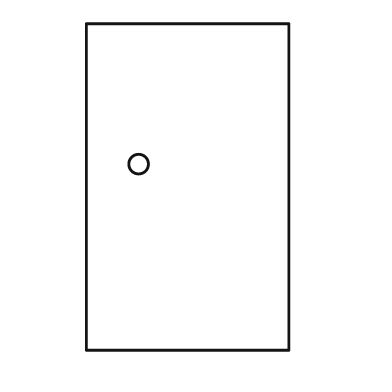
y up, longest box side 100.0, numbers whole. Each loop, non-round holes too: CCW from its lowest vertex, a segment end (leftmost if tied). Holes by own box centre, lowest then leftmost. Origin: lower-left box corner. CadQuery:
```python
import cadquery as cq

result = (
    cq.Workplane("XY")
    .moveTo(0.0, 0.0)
    .lineTo(62.0, 0.0)
    .lineTo(62.0, 100.0)
    .lineTo(0.0, 100.0)
    .close()
    .moveTo(16.0, 57.0)
    .circle(3.0)
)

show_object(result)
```